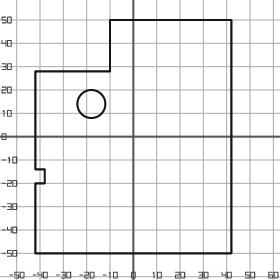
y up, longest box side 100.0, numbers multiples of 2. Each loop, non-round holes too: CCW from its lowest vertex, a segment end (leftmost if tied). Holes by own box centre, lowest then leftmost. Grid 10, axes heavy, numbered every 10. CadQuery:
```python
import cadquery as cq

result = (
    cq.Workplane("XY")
    .moveTo(-42.0, -50.0)
    .lineTo(42.0, -50.0)
    .lineTo(42.0, 50.0)
    .lineTo(-10.0, 50.0)
    .lineTo(-10.0, 28.0)
    .lineTo(-42.0, 28.0)
    .lineTo(-42.0, -14.0)
    .lineTo(-38.0, -14.0)
    .lineTo(-38.0, -20.0)
    .lineTo(-42.0, -20.0)
    .close()
    .moveTo(-18.0, 14.0)
    .circle(6.0)
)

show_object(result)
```